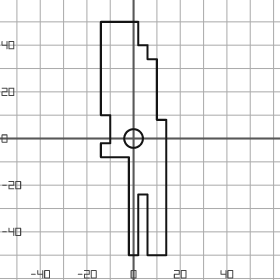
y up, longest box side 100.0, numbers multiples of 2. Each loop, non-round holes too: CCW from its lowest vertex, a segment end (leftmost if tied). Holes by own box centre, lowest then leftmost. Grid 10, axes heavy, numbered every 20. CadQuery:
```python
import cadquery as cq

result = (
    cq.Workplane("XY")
    .moveTo(-2.0, -50.0)
    .lineTo(2.0, -50.0)
    .lineTo(2.0, -24.0)
    .lineTo(6.0, -24.0)
    .lineTo(6.0, -50.0)
    .lineTo(14.0, -50.0)
    .lineTo(14.0, 8.0)
    .lineTo(10.0, 8.0)
    .lineTo(10.0, 34.0)
    .lineTo(6.0, 34.0)
    .lineTo(6.0, 40.0)
    .lineTo(2.0, 40.0)
    .lineTo(2.0, 50.0)
    .lineTo(-14.0, 50.0)
    .lineTo(-14.0, 10.0)
    .lineTo(-10.0, 10.0)
    .lineTo(-10.0, -2.0)
    .lineTo(-14.0, -2.0)
    .lineTo(-14.0, -8.0)
    .lineTo(-2.0, -8.0)
    .close()
    .moveTo(0.0, 0.0)
    .circle(4.0)
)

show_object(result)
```